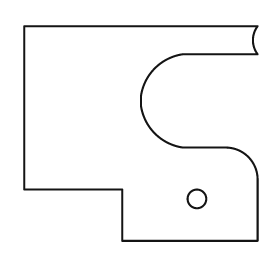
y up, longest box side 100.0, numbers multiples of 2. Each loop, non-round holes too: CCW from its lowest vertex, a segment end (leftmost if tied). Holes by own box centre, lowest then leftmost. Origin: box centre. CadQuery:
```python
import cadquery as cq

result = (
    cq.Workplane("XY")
    .moveTo(-8.0, -46.0)
    .lineTo(50.0, -46.0)
    .lineTo(50.0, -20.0)
    .threePointArc((46.0, -10.0), (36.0, -6.0))
    .lineTo(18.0, -6.0)
    .threePointArc((6.0, 0.0), (0.0, 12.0))
    .lineTo(0.0, 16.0)
    .threePointArc((6.0, 28.0), (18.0, 34.0))
    .lineTo(50.0, 34.0)
    .threePointArc((48.0, 40.0), (50.0, 46.0))
    .lineTo(-50.0, 46.0)
    .lineTo(-50.0, -24.0)
    .lineTo(-8.0, -24.0)
    .close()
    .moveTo(24.0, -28.0)
    .circle(4.0)
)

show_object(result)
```